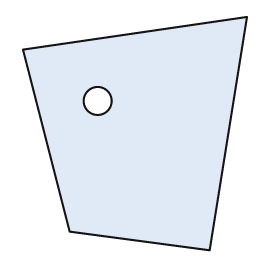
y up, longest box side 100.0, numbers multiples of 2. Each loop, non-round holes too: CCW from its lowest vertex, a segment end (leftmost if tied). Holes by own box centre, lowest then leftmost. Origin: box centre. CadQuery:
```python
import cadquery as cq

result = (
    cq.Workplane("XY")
    .moveTo(32.0, -50.0)
    .lineTo(48.0, 50.0)
    .lineTo(-48.0, 36.0)
    .lineTo(-28.0, -42.0)
    .close()
    .moveTo(-16.0, 14.0)
    .circle(6.0)
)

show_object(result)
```